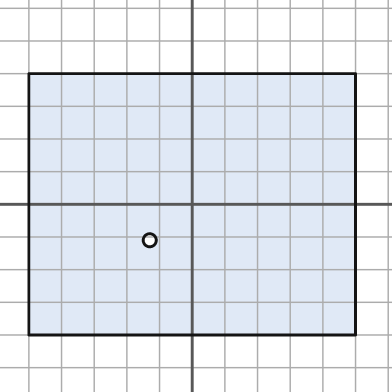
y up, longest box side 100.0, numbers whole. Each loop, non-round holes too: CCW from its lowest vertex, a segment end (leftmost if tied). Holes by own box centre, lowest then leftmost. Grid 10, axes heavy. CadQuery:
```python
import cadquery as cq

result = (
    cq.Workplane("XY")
    .moveTo(-50.0, -40.0)
    .lineTo(50.0, -40.0)
    .lineTo(50.0, 40.0)
    .lineTo(-50.0, 40.0)
    .close()
    .moveTo(-13.0, -11.0)
    .circle(2.0)
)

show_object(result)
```